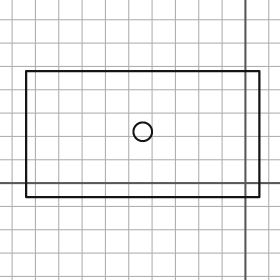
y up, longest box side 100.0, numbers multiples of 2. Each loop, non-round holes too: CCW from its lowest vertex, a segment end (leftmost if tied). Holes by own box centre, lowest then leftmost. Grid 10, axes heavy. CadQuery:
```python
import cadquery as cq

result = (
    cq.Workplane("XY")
    .moveTo(-94.0, -6.0)
    .lineTo(6.0, -6.0)
    .lineTo(6.0, 48.0)
    .lineTo(-94.0, 48.0)
    .close()
    .moveTo(-44.0, 22.0)
    .circle(4.0)
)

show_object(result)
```